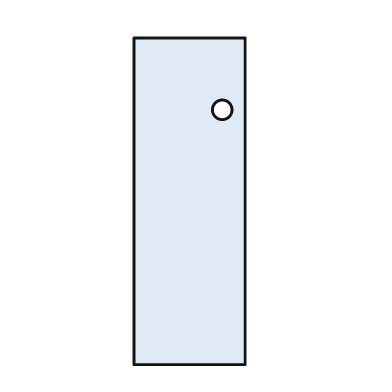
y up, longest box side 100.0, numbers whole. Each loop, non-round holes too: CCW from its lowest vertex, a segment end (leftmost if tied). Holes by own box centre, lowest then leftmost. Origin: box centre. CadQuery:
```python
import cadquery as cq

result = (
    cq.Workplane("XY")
    .moveTo(-17.0, -50.0)
    .lineTo(17.0, -50.0)
    .lineTo(17.0, 50.0)
    .lineTo(-17.0, 50.0)
    .close()
    .moveTo(10.0, 28.0)
    .circle(3.0)
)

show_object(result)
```